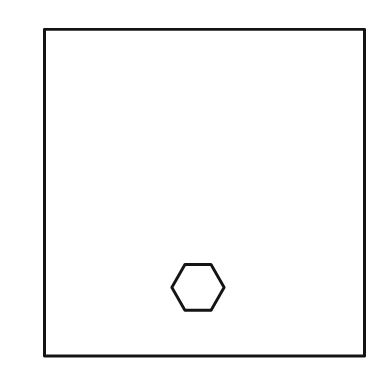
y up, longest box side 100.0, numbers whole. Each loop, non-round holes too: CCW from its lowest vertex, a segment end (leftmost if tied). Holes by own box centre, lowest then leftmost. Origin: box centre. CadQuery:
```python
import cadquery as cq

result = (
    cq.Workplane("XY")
    .moveTo(-49.0, -50.0)
    .lineTo(49.0, -50.0)
    .lineTo(49.0, 50.0)
    .lineTo(-49.0, 50.0)
    .close()
    .moveTo(-6.0, -36.0)
    .lineTo(2.0, -36.0)
    .lineTo(6.0, -29.0)
    .lineTo(2.0, -22.0)
    .lineTo(-6.0, -22.0)
    .lineTo(-10.0, -29.0)
    .close()
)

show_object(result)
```